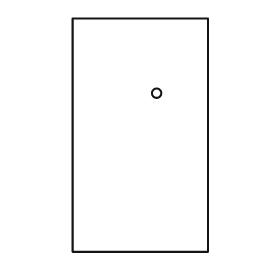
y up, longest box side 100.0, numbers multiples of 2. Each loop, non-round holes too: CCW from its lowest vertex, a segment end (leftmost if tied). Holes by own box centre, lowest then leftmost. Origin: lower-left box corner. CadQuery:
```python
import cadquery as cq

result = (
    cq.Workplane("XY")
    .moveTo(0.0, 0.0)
    .lineTo(58.0, 0.0)
    .lineTo(58.0, 100.0)
    .lineTo(0.0, 100.0)
    .close()
    .moveTo(36.0, 68.0)
    .circle(2.0)
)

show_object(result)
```